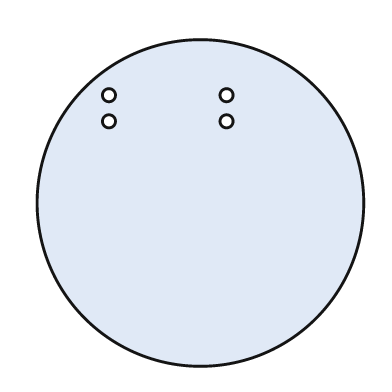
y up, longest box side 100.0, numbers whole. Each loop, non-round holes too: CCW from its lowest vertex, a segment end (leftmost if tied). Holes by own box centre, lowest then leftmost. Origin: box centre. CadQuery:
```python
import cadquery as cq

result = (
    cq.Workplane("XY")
    .moveTo(0.0, 0.0)
    .circle(50.0)
    .moveTo(-28.0, 25.0)
    .circle(2.0)
    .moveTo(8.0, 25.0)
    .circle(2.0)
    .moveTo(-28.0, 33.0)
    .circle(2.0)
    .moveTo(8.0, 33.0)
    .circle(2.0)
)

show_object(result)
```